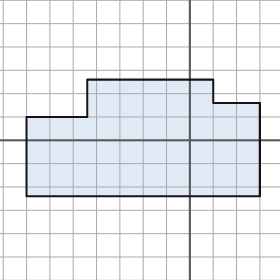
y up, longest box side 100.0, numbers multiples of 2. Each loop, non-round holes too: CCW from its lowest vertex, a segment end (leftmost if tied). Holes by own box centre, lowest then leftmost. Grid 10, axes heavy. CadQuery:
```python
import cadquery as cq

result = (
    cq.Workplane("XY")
    .moveTo(-70.0, -24.0)
    .lineTo(30.0, -24.0)
    .lineTo(30.0, 16.0)
    .lineTo(10.0, 16.0)
    .lineTo(10.0, 26.0)
    .lineTo(-44.0, 26.0)
    .lineTo(-44.0, 10.0)
    .lineTo(-70.0, 10.0)
    .close()
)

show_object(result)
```